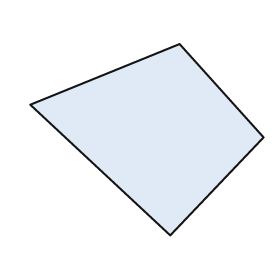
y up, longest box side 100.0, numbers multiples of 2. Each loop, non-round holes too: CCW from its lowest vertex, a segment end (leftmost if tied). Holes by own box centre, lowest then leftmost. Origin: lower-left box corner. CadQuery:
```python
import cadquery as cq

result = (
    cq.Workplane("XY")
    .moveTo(60.0, 0.0)
    .lineTo(100.0, 42.0)
    .lineTo(64.0, 82.0)
    .lineTo(0.0, 56.0)
    .close()
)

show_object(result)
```